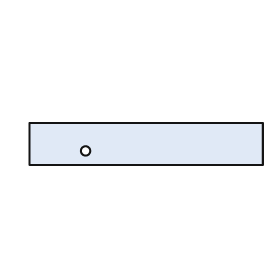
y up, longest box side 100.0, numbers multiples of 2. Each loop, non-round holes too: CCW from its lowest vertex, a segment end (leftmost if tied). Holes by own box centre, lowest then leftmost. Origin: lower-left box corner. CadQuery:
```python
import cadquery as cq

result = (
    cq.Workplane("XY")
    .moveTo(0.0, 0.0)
    .lineTo(100.0, 0.0)
    .lineTo(100.0, 18.0)
    .lineTo(0.0, 18.0)
    .close()
    .moveTo(24.0, 6.0)
    .circle(2.0)
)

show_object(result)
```